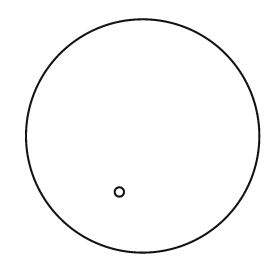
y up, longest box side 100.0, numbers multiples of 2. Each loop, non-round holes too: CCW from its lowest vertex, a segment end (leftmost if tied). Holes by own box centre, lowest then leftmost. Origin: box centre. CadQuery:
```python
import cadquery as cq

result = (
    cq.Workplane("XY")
    .moveTo(0.0, 0.0)
    .circle(50.0)
    .moveTo(-10.0, -24.0)
    .circle(2.0)
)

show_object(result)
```